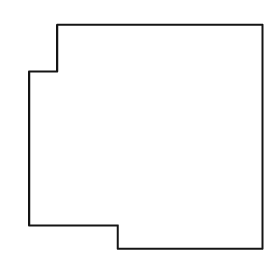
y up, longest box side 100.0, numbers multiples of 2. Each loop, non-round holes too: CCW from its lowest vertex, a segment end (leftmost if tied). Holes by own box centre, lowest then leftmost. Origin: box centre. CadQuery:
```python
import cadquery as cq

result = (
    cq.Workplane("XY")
    .moveTo(-12.0, -48.0)
    .lineTo(50.0, -48.0)
    .lineTo(50.0, 48.0)
    .lineTo(-38.0, 48.0)
    .lineTo(-38.0, 28.0)
    .lineTo(-50.0, 28.0)
    .lineTo(-50.0, -38.0)
    .lineTo(-12.0, -38.0)
    .close()
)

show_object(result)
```